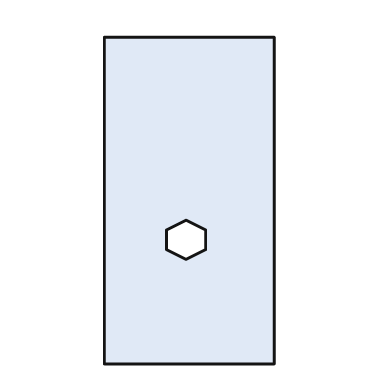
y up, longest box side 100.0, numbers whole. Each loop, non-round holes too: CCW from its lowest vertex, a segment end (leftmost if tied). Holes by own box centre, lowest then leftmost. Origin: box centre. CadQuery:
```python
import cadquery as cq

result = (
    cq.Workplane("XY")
    .moveTo(-26.0, -50.0)
    .lineTo(26.0, -50.0)
    .lineTo(26.0, 50.0)
    .lineTo(-26.0, 50.0)
    .close()
    .moveTo(-1.0, -18.0)
    .lineTo(5.0, -15.0)
    .lineTo(5.0, -9.0)
    .lineTo(-1.0, -6.0)
    .lineTo(-7.0, -9.0)
    .lineTo(-7.0, -15.0)
    .close()
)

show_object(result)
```